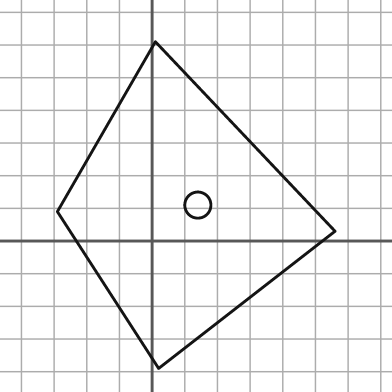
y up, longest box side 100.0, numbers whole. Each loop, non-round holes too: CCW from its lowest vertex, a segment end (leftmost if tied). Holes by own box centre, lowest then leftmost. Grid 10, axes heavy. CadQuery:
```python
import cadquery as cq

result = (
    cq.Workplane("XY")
    .moveTo(2.0, -39.0)
    .lineTo(56.0, 3.0)
    .lineTo(1.0, 61.0)
    .lineTo(-29.0, 9.0)
    .close()
    .moveTo(14.0, 11.0)
    .circle(4.0)
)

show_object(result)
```